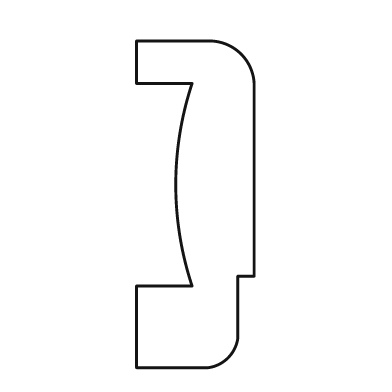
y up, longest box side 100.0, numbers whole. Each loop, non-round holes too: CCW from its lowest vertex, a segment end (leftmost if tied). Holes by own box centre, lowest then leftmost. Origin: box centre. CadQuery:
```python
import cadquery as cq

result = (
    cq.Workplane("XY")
    .moveTo(-18.0, -50.0)
    .lineTo(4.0, -50.0)
    .threePointArc((10.0, -47.0), (13.0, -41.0))
    .lineTo(13.0, -22.0)
    .lineTo(18.0, -22.0)
    .lineTo(18.0, 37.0)
    .threePointArc((14.0, 46.0), (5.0, 50.0))
    .lineTo(-18.0, 50.0)
    .lineTo(-18.0, 37.0)
    .lineTo(-1.0, 37.0)
    .threePointArc((-6.0, 6.0), (-1.0, -25.0))
    .lineTo(-18.0, -25.0)
    .close()
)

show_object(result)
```